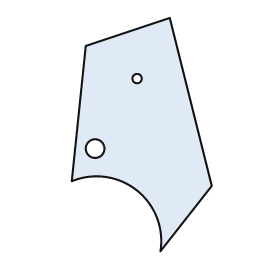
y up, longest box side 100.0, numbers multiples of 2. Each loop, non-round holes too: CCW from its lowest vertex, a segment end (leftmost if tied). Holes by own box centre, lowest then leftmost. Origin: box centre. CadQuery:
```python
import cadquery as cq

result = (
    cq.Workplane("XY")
    .moveTo(8.0, -50.0)
    .lineTo(30.0, -22.0)
    .lineTo(12.0, 50.0)
    .lineTo(-24.0, 38.0)
    .lineTo(-30.0, -20.0)
    .threePointArc((-2.0, -24.0), (8.0, -50.0))
    .close()
    .moveTo(-20.0, -6.0)
    .circle(4.0)
    .moveTo(-2.0, 24.0)
    .circle(2.0)
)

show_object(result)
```